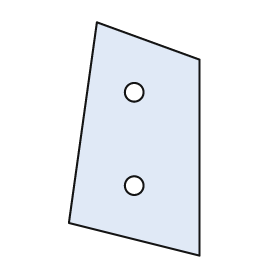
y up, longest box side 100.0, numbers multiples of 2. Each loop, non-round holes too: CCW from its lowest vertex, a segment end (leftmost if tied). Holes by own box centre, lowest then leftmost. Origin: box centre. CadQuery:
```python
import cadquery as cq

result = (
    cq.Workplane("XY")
    .moveTo(28.0, -50.0)
    .lineTo(28.0, 34.0)
    .lineTo(-16.0, 50.0)
    .lineTo(-28.0, -36.0)
    .close()
    .moveTo(0.0, -20.0)
    .circle(4.0)
    .moveTo(0.0, 20.0)
    .circle(4.0)
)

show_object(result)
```